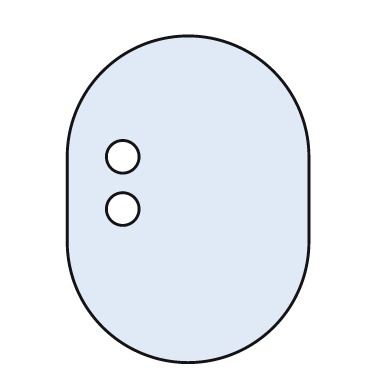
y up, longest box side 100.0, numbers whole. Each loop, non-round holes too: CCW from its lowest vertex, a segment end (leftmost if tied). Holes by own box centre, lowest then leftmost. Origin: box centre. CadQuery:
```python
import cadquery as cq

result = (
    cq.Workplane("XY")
    .moveTo(-37.0, -13.0)
    .threePointArc((0.0, -50.0), (37.0, -13.0))
    .lineTo(37.0, 13.0)
    .threePointArc((0.0, 50.0), (-37.0, 13.0))
    .close()
    .moveTo(-20.0, -3.0)
    .circle(5.0)
    .moveTo(-20.0, 13.0)
    .circle(5.0)
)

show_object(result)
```